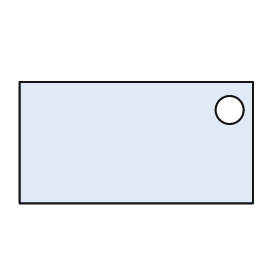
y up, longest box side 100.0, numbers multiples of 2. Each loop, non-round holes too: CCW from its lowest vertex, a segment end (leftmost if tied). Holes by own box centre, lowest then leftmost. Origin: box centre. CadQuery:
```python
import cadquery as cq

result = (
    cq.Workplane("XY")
    .moveTo(-50.0, -26.0)
    .lineTo(50.0, -26.0)
    .lineTo(50.0, 26.0)
    .lineTo(-50.0, 26.0)
    .close()
    .moveTo(40.0, 14.0)
    .circle(6.0)
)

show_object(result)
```